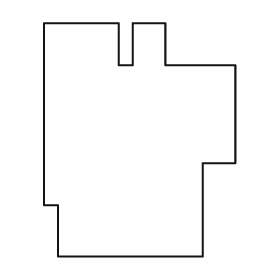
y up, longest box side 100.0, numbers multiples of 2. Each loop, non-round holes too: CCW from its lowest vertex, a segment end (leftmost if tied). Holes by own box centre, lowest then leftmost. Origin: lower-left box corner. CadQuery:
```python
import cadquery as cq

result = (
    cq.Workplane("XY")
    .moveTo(6.0, 0.0)
    .lineTo(68.0, 0.0)
    .lineTo(68.0, 40.0)
    .lineTo(82.0, 40.0)
    .lineTo(82.0, 82.0)
    .lineTo(52.0, 82.0)
    .lineTo(52.0, 100.0)
    .lineTo(38.0, 100.0)
    .lineTo(38.0, 82.0)
    .lineTo(32.0, 82.0)
    .lineTo(32.0, 100.0)
    .lineTo(0.0, 100.0)
    .lineTo(0.0, 22.0)
    .lineTo(6.0, 22.0)
    .close()
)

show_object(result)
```